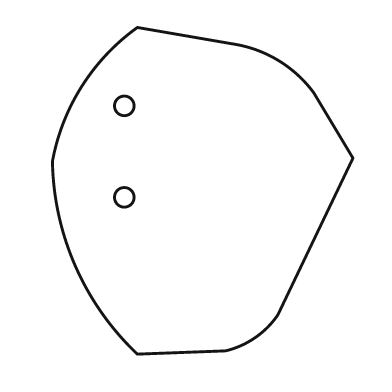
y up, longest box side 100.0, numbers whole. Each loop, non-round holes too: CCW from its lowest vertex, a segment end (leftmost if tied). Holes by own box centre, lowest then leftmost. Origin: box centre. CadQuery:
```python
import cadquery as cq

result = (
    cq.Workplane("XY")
    .moveTo(-20.0, -50.0)
    .lineTo(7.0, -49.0)
    .threePointArc((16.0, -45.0), (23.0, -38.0))
    .lineTo(46.0, 10.0)
    .lineTo(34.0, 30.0)
    .threePointArc((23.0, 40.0), (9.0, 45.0))
    .lineTo(-20.0, 50.0)
    .threePointArc((-37.0, 32.0), (-46.0, 9.0))
    .threePointArc((-39.0, -23.0), (-20.0, -50.0))
    .close()
    .moveTo(-24.0, -2.0)
    .circle(3.0)
    .moveTo(-24.0, 26.0)
    .circle(3.0)
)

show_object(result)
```